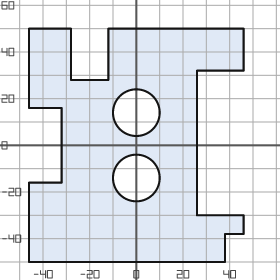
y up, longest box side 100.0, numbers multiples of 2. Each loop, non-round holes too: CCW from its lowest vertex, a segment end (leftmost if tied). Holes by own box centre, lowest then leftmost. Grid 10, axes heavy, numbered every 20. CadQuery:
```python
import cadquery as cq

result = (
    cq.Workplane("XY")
    .moveTo(-46.0, -50.0)
    .lineTo(38.0, -50.0)
    .lineTo(38.0, -38.0)
    .lineTo(46.0, -38.0)
    .lineTo(46.0, -30.0)
    .lineTo(26.0, -30.0)
    .lineTo(26.0, 32.0)
    .lineTo(46.0, 32.0)
    .lineTo(46.0, 50.0)
    .lineTo(-12.0, 50.0)
    .lineTo(-12.0, 28.0)
    .lineTo(-28.0, 28.0)
    .lineTo(-28.0, 50.0)
    .lineTo(-46.0, 50.0)
    .lineTo(-46.0, 16.0)
    .lineTo(-32.0, 16.0)
    .lineTo(-32.0, -16.0)
    .lineTo(-46.0, -16.0)
    .close()
    .moveTo(0.0, -14.0)
    .circle(10.0)
    .moveTo(0.0, 14.0)
    .circle(10.0)
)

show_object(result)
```